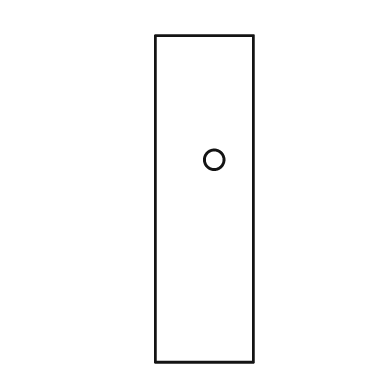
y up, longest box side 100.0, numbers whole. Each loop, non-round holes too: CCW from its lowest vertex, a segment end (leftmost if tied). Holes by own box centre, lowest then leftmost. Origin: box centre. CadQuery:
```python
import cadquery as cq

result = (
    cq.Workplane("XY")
    .moveTo(-15.0, -50.0)
    .lineTo(15.0, -50.0)
    .lineTo(15.0, 50.0)
    .lineTo(-15.0, 50.0)
    .close()
    .moveTo(3.0, 12.0)
    .circle(3.0)
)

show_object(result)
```